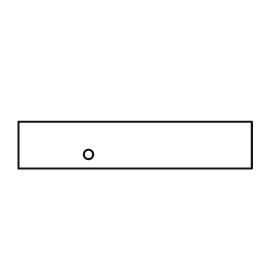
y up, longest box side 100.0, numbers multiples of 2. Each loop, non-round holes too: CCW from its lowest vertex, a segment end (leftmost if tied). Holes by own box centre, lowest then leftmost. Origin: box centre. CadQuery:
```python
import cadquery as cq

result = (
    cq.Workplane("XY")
    .moveTo(-50.0, -10.0)
    .lineTo(50.0, -10.0)
    .lineTo(50.0, 10.0)
    .lineTo(-50.0, 10.0)
    .close()
    .moveTo(-20.0, -4.0)
    .circle(2.0)
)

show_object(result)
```